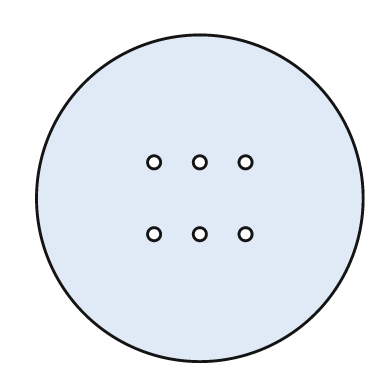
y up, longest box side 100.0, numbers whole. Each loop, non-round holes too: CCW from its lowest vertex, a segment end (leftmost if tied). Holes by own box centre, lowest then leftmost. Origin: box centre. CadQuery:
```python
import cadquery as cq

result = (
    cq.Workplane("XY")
    .moveTo(0.0, 0.0)
    .circle(50.0)
    .moveTo(-14.0, -11.0)
    .circle(2.0)
    .moveTo(0.0, -11.0)
    .circle(2.0)
    .moveTo(14.0, -11.0)
    .circle(2.0)
    .moveTo(-14.0, 11.0)
    .circle(2.0)
    .moveTo(0.0, 11.0)
    .circle(2.0)
    .moveTo(14.0, 11.0)
    .circle(2.0)
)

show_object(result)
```